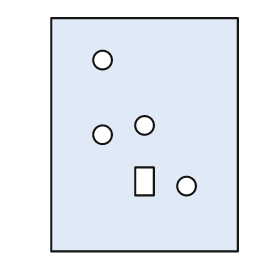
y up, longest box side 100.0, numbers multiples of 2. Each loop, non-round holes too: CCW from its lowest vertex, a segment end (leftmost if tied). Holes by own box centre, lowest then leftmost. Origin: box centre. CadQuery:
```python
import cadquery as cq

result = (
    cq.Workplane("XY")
    .moveTo(-40.0, -50.0)
    .lineTo(40.0, -50.0)
    .lineTo(40.0, 50.0)
    .lineTo(-40.0, 50.0)
    .close()
    .moveTo(18.0, -22.0)
    .circle(4.0)
    .moveTo(-4.0, -26.0)
    .lineTo(4.0, -26.0)
    .lineTo(4.0, -14.0)
    .lineTo(-4.0, -14.0)
    .close()
    .moveTo(-18.0, 0.0)
    .circle(4.0)
    .moveTo(0.0, 4.0)
    .circle(4.0)
    .moveTo(-18.0, 32.0)
    .circle(4.0)
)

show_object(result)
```